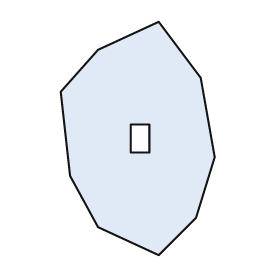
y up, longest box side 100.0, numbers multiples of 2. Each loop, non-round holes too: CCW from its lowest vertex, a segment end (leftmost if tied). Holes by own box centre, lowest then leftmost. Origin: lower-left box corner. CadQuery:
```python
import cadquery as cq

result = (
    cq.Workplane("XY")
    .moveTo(42.0, 0.0)
    .lineTo(58.0, 16.0)
    .lineTo(66.0, 42.0)
    .lineTo(60.0, 76.0)
    .lineTo(42.0, 100.0)
    .lineTo(16.0, 88.0)
    .lineTo(0.0, 70.0)
    .lineTo(4.0, 34.0)
    .lineTo(16.0, 12.0)
    .close()
    .moveTo(30.0, 44.0)
    .lineTo(38.0, 44.0)
    .lineTo(38.0, 56.0)
    .lineTo(30.0, 56.0)
    .close()
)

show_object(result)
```